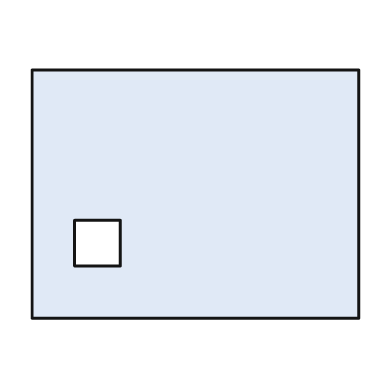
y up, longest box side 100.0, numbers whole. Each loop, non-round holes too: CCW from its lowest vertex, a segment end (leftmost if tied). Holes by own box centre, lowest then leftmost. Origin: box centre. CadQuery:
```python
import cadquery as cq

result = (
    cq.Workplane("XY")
    .moveTo(-50.0, -38.0)
    .lineTo(50.0, -38.0)
    .lineTo(50.0, 38.0)
    .lineTo(-50.0, 38.0)
    .close()
    .moveTo(-37.0, -22.0)
    .lineTo(-23.0, -22.0)
    .lineTo(-23.0, -8.0)
    .lineTo(-37.0, -8.0)
    .close()
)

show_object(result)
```